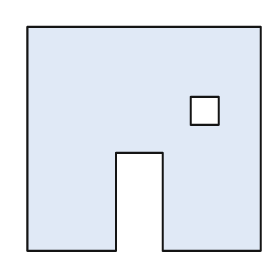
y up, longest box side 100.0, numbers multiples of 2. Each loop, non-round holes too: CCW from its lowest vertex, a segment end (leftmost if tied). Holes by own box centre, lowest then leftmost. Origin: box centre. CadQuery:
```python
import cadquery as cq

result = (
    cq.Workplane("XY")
    .moveTo(-50.0, -48.0)
    .lineTo(-12.0, -48.0)
    .lineTo(-12.0, -6.0)
    .lineTo(8.0, -6.0)
    .lineTo(8.0, -48.0)
    .lineTo(50.0, -48.0)
    .lineTo(50.0, 48.0)
    .lineTo(-50.0, 48.0)
    .close()
    .moveTo(20.0, 6.0)
    .lineTo(32.0, 6.0)
    .lineTo(32.0, 18.0)
    .lineTo(20.0, 18.0)
    .close()
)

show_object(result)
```